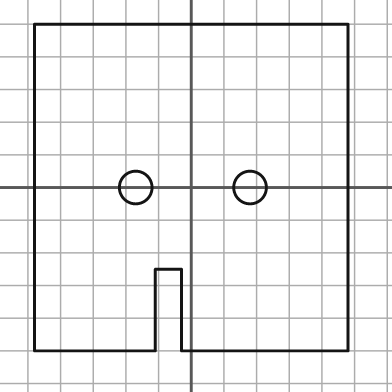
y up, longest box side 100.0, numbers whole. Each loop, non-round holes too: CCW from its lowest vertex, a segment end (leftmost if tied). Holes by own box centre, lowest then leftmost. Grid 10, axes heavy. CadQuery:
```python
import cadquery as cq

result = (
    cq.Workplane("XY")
    .moveTo(-48.0, -50.0)
    .lineTo(-11.0, -50.0)
    .lineTo(-11.0, -25.0)
    .lineTo(-3.0, -25.0)
    .lineTo(-3.0, -50.0)
    .lineTo(48.0, -50.0)
    .lineTo(48.0, 50.0)
    .lineTo(-48.0, 50.0)
    .close()
    .moveTo(-17.0, 0.0)
    .circle(5.0)
    .moveTo(18.0, 0.0)
    .circle(5.0)
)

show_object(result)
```